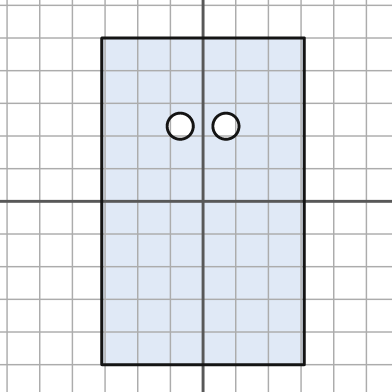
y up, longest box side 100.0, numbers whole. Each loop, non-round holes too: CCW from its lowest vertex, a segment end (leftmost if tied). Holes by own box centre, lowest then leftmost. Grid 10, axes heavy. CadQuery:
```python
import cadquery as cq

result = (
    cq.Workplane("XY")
    .moveTo(-31.0, -50.0)
    .lineTo(31.0, -50.0)
    .lineTo(31.0, 50.0)
    .lineTo(-31.0, 50.0)
    .close()
    .moveTo(-7.0, 23.0)
    .circle(4.0)
    .moveTo(7.0, 23.0)
    .circle(4.0)
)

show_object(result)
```